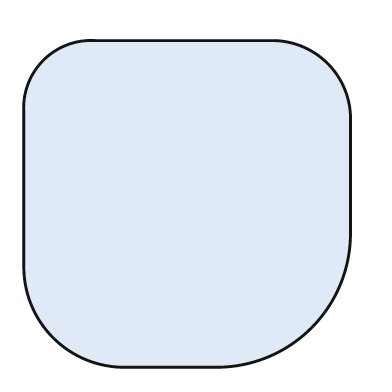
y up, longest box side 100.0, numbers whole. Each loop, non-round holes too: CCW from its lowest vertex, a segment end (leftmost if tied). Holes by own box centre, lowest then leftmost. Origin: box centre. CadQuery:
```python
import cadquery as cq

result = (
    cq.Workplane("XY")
    .moveTo(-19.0, -50.0)
    .lineTo(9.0, -50.0)
    .threePointArc((38.0, -38.0), (50.0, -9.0))
    .lineTo(50.0, 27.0)
    .threePointArc((43.0, 43.0), (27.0, 50.0))
    .lineTo(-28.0, 50.0)
    .threePointArc((-44.0, 44.0), (-50.0, 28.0))
    .lineTo(-50.0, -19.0)
    .threePointArc((-41.0, -41.0), (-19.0, -50.0))
    .close()
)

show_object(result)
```